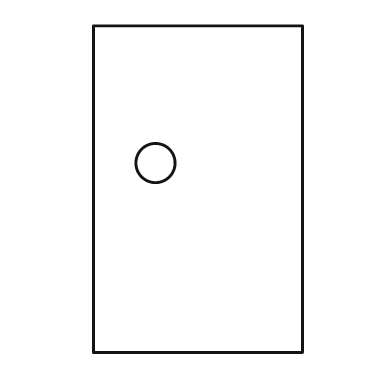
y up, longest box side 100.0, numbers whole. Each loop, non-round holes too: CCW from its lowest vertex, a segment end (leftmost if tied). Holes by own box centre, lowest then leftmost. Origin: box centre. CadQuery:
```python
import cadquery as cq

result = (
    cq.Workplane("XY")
    .moveTo(-32.0, -50.0)
    .lineTo(32.0, -50.0)
    .lineTo(32.0, 50.0)
    .lineTo(-32.0, 50.0)
    .close()
    .moveTo(-13.0, 8.0)
    .circle(6.0)
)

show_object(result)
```